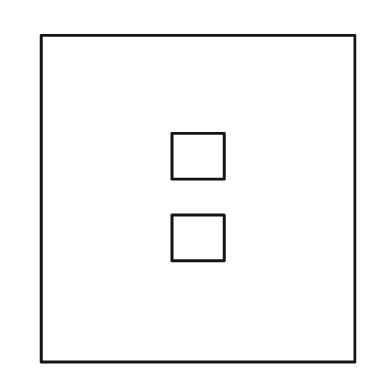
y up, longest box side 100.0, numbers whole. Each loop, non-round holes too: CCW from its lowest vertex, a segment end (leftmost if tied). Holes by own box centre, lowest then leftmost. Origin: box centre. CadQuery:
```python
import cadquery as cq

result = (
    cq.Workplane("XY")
    .moveTo(-48.0, -50.0)
    .lineTo(48.0, -50.0)
    .lineTo(48.0, 50.0)
    .lineTo(-48.0, 50.0)
    .close()
    .moveTo(-8.0, -19.0)
    .lineTo(8.0, -19.0)
    .lineTo(8.0, -5.0)
    .lineTo(-8.0, -5.0)
    .close()
    .moveTo(-8.0, 6.0)
    .lineTo(8.0, 6.0)
    .lineTo(8.0, 20.0)
    .lineTo(-8.0, 20.0)
    .close()
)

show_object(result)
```